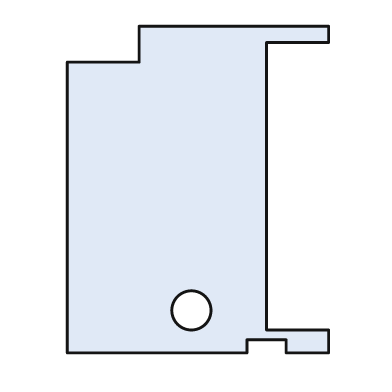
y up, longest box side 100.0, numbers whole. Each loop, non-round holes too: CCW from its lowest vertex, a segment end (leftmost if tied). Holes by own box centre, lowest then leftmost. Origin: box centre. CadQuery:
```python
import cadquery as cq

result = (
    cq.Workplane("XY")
    .moveTo(-40.0, -50.0)
    .lineTo(15.0, -50.0)
    .lineTo(15.0, -46.0)
    .lineTo(27.0, -46.0)
    .lineTo(27.0, -50.0)
    .lineTo(40.0, -50.0)
    .lineTo(40.0, -43.0)
    .lineTo(21.0, -43.0)
    .lineTo(21.0, 45.0)
    .lineTo(40.0, 45.0)
    .lineTo(40.0, 50.0)
    .lineTo(-18.0, 50.0)
    .lineTo(-18.0, 39.0)
    .lineTo(-40.0, 39.0)
    .close()
    .moveTo(-2.0, -37.0)
    .circle(6.0)
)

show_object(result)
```